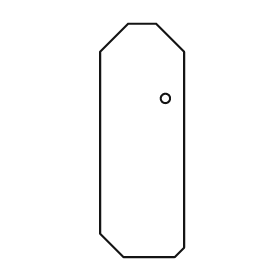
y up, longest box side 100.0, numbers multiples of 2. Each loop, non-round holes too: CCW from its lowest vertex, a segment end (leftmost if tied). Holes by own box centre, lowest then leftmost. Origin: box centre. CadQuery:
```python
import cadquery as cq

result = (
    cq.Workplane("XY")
    .moveTo(-8.0, -50.0)
    .lineTo(14.0, -50.0)
    .lineTo(18.0, -46.0)
    .lineTo(18.0, 38.0)
    .lineTo(6.0, 50.0)
    .lineTo(-6.0, 50.0)
    .lineTo(-18.0, 38.0)
    .lineTo(-18.0, -40.0)
    .close()
    .moveTo(10.0, 18.0)
    .circle(2.0)
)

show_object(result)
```